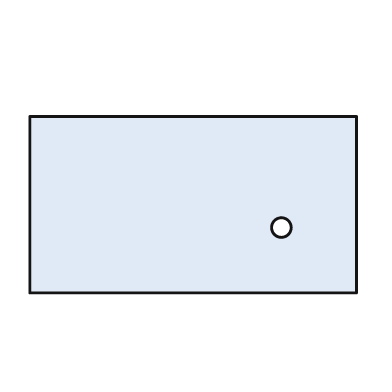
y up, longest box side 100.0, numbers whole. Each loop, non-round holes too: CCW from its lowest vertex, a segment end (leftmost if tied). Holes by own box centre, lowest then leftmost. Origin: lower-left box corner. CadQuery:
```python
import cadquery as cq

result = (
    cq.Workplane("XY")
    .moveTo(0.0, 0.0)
    .lineTo(100.0, 0.0)
    .lineTo(100.0, 54.0)
    .lineTo(0.0, 54.0)
    .close()
    .moveTo(77.0, 20.0)
    .circle(3.0)
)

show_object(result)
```